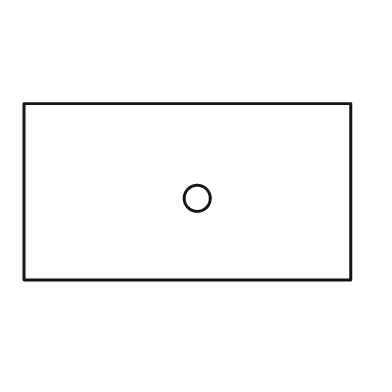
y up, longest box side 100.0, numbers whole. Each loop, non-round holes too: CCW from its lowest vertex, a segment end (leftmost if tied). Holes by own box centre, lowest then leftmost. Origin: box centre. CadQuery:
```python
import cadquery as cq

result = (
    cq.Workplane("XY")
    .moveTo(-50.0, -27.0)
    .lineTo(50.0, -27.0)
    .lineTo(50.0, 27.0)
    .lineTo(-50.0, 27.0)
    .close()
    .moveTo(3.0, -2.0)
    .circle(4.0)
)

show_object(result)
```